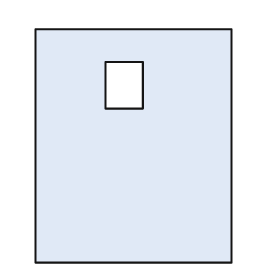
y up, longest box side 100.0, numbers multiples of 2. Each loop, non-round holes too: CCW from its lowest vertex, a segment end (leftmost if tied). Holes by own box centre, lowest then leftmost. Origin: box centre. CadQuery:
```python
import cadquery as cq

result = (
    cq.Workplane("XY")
    .moveTo(-42.0, -50.0)
    .lineTo(42.0, -50.0)
    .lineTo(42.0, 50.0)
    .lineTo(-42.0, 50.0)
    .close()
    .moveTo(-12.0, 16.0)
    .lineTo(4.0, 16.0)
    .lineTo(4.0, 36.0)
    .lineTo(-12.0, 36.0)
    .close()
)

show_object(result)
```